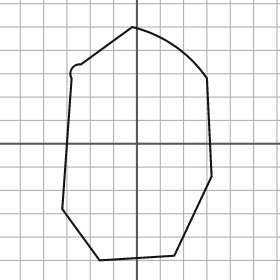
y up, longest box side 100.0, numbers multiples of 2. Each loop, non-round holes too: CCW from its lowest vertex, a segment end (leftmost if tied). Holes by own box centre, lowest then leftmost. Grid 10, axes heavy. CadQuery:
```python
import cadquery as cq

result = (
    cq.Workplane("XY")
    .moveTo(-16.0, -50.0)
    .lineTo(16.0, -48.0)
    .lineTo(32.0, -14.0)
    .lineTo(30.0, 28.0)
    .threePointArc((16.0, 42.0), (-2.0, 50.0))
    .lineTo(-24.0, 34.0)
    .threePointArc((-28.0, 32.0), (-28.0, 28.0))
    .lineTo(-32.0, -28.0)
    .close()
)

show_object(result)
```